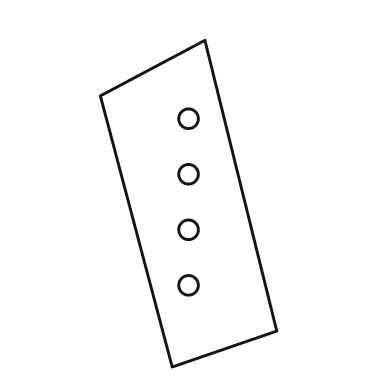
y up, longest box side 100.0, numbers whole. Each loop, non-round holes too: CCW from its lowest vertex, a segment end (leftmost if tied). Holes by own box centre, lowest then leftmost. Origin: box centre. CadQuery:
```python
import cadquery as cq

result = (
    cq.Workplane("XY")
    .moveTo(-5.0, -50.0)
    .lineTo(27.0, -39.0)
    .lineTo(5.0, 50.0)
    .lineTo(-27.0, 33.0)
    .close()
    .moveTo(0.0, -25.0)
    .circle(3.0)
    .moveTo(0.0, -8.0)
    .circle(3.0)
    .moveTo(0.0, 9.0)
    .circle(3.0)
    .moveTo(0.0, 26.0)
    .circle(3.0)
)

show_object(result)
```